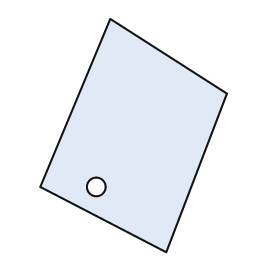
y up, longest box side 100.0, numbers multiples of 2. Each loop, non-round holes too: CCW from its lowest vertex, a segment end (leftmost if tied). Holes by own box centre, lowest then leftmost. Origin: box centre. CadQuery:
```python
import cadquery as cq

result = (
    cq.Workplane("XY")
    .moveTo(14.0, -50.0)
    .lineTo(40.0, 18.0)
    .lineTo(-10.0, 50.0)
    .lineTo(-40.0, -22.0)
    .close()
    .moveTo(-16.0, -22.0)
    .circle(4.0)
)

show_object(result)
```